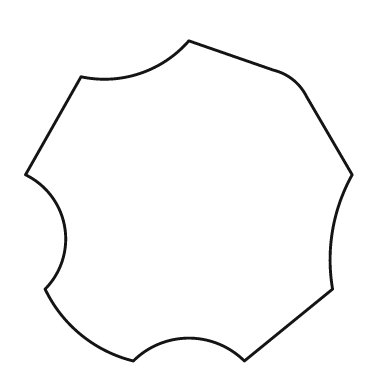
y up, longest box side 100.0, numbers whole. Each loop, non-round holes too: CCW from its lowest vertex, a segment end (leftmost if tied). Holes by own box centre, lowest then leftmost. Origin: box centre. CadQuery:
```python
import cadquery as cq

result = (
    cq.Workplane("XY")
    .moveTo(-17.0, -49.0)
    .threePointArc((0.0, -42.0), (17.0, -49.0))
    .lineTo(44.0, -27.0)
    .threePointArc((44.0, -9.0), (50.0, 8.0))
    .lineTo(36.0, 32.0)
    .threePointArc((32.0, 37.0), (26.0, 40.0))
    .lineTo(0.0, 49.0)
    .threePointArc((-15.0, 39.0), (-33.0, 38.0))
    .lineTo(-50.0, 8.0)
    .threePointArc((-38.0, -8.0), (-44.0, -27.0))
    .threePointArc((-33.0, -41.0), (-17.0, -49.0))
    .close()
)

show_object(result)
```